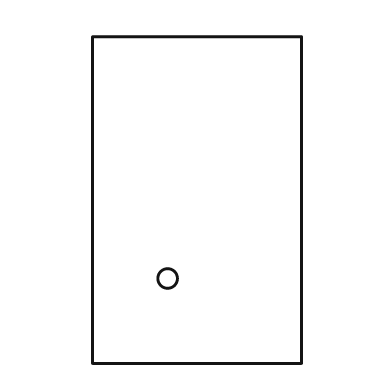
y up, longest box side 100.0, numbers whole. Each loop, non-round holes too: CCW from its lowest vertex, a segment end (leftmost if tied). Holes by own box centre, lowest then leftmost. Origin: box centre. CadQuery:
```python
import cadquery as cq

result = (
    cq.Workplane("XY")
    .moveTo(-32.0, -50.0)
    .lineTo(32.0, -50.0)
    .lineTo(32.0, 50.0)
    .lineTo(-32.0, 50.0)
    .close()
    .moveTo(-9.0, -24.0)
    .circle(3.0)
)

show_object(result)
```